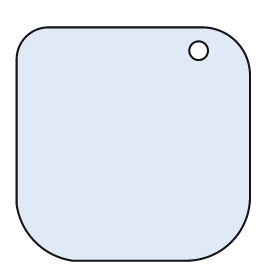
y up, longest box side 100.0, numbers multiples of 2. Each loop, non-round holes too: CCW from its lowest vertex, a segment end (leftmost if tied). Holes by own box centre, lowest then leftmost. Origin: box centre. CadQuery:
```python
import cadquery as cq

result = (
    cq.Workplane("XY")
    .moveTo(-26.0, -50.0)
    .lineTo(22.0, -50.0)
    .threePointArc((42.0, -42.0), (50.0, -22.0))
    .lineTo(50.0, 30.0)
    .threePointArc((44.0, 44.0), (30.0, 50.0))
    .lineTo(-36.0, 50.0)
    .threePointArc((-46.0, 46.0), (-50.0, 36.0))
    .lineTo(-50.0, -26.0)
    .threePointArc((-42.0, -42.0), (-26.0, -50.0))
    .close()
    .moveTo(28.0, 40.0)
    .circle(4.0)
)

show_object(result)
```